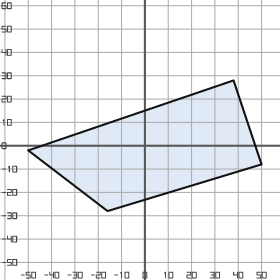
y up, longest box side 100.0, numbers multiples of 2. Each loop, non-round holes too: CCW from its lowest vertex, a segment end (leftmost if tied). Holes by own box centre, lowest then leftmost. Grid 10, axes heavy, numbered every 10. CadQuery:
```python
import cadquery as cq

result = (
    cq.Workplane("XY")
    .moveTo(-16.0, -28.0)
    .lineTo(50.0, -8.0)
    .lineTo(38.0, 28.0)
    .lineTo(-50.0, -2.0)
    .close()
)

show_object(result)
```